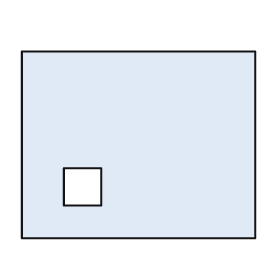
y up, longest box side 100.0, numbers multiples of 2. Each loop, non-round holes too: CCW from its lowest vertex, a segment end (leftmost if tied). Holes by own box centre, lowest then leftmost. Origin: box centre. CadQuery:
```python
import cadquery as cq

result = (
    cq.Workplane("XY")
    .moveTo(-50.0, -40.0)
    .lineTo(50.0, -40.0)
    .lineTo(50.0, 40.0)
    .lineTo(-50.0, 40.0)
    .close()
    .moveTo(-32.0, -26.0)
    .lineTo(-16.0, -26.0)
    .lineTo(-16.0, -10.0)
    .lineTo(-32.0, -10.0)
    .close()
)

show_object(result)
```